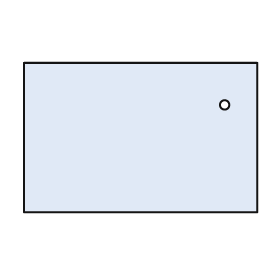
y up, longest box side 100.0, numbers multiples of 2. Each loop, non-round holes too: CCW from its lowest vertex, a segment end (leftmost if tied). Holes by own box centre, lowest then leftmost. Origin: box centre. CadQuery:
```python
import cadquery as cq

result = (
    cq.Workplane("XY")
    .moveTo(-50.0, -32.0)
    .lineTo(50.0, -32.0)
    .lineTo(50.0, 32.0)
    .lineTo(-50.0, 32.0)
    .close()
    .moveTo(36.0, 14.0)
    .circle(2.0)
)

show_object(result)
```